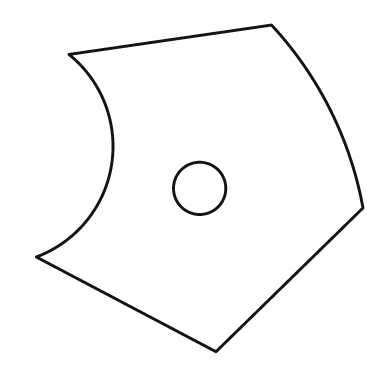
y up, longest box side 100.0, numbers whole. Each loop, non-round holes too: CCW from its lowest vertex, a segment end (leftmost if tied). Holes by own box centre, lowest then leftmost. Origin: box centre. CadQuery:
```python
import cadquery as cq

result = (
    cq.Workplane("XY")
    .moveTo(5.0, -50.0)
    .lineTo(50.0, -6.0)
    .threePointArc((40.0, 24.0), (22.0, 50.0))
    .lineTo(-40.0, 41.0)
    .threePointArc((-27.0, 7.0), (-50.0, -21.0))
    .close()
    .moveTo(0.0, 0.0)
    .circle(8.0)
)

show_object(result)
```